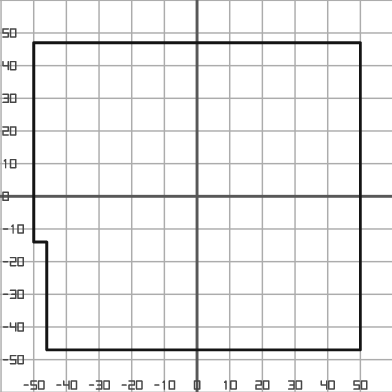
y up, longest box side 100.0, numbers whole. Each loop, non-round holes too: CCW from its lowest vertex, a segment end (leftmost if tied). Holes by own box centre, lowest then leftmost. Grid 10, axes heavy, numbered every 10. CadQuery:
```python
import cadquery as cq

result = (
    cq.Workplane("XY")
    .moveTo(-46.0, -47.0)
    .lineTo(50.0, -47.0)
    .lineTo(50.0, 47.0)
    .lineTo(-50.0, 47.0)
    .lineTo(-50.0, -14.0)
    .lineTo(-46.0, -14.0)
    .close()
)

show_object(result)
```